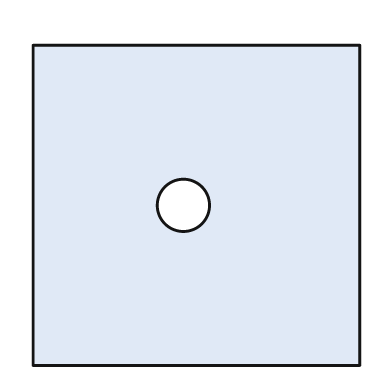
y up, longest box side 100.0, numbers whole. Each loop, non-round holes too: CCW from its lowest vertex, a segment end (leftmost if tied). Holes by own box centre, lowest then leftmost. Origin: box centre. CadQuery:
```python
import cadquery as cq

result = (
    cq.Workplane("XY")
    .moveTo(-50.0, -49.0)
    .lineTo(50.0, -49.0)
    .lineTo(50.0, 49.0)
    .lineTo(-50.0, 49.0)
    .close()
    .moveTo(-4.0, 0.0)
    .circle(8.0)
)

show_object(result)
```